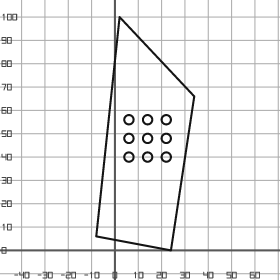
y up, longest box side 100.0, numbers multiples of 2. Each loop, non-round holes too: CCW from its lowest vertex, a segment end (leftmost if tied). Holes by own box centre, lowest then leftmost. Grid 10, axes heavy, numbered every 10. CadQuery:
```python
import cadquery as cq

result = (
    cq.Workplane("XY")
    .moveTo(24.0, 0.0)
    .lineTo(34.0, 66.0)
    .lineTo(2.0, 100.0)
    .lineTo(-8.0, 6.0)
    .close()
    .moveTo(6.0, 40.0)
    .circle(2.0)
    .moveTo(14.0, 40.0)
    .circle(2.0)
    .moveTo(22.0, 40.0)
    .circle(2.0)
    .moveTo(6.0, 48.0)
    .circle(2.0)
    .moveTo(14.0, 48.0)
    .circle(2.0)
    .moveTo(22.0, 48.0)
    .circle(2.0)
    .moveTo(6.0, 56.0)
    .circle(2.0)
    .moveTo(14.0, 56.0)
    .circle(2.0)
    .moveTo(22.0, 56.0)
    .circle(2.0)
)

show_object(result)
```